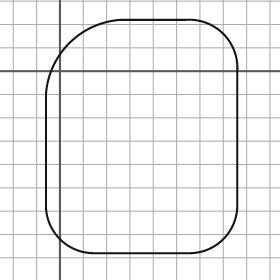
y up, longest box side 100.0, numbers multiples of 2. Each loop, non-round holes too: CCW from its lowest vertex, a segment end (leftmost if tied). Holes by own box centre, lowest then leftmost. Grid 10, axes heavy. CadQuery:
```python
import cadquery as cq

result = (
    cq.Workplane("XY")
    .moveTo(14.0, -78.0)
    .lineTo(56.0, -78.0)
    .threePointArc((70.0, -72.0), (76.0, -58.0))
    .lineTo(76.0, 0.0)
    .threePointArc((70.0, 16.0), (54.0, 22.0))
    .lineTo(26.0, 22.0)
    .threePointArc((4.0, 12.0), (-6.0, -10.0))
    .lineTo(-6.0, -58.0)
    .threePointArc((0.0, -72.0), (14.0, -78.0))
    .close()
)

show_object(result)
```